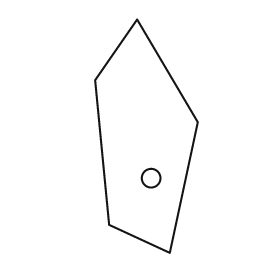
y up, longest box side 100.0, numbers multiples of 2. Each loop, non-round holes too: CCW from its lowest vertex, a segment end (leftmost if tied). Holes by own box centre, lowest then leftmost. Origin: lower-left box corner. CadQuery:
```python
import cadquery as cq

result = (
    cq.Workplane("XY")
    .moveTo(32.0, 0.0)
    .lineTo(44.0, 56.0)
    .lineTo(18.0, 100.0)
    .lineTo(0.0, 74.0)
    .lineTo(6.0, 12.0)
    .close()
    .moveTo(24.0, 32.0)
    .circle(4.0)
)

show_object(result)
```